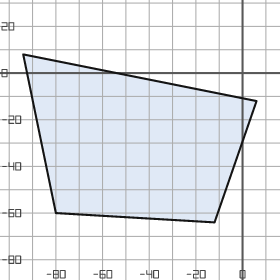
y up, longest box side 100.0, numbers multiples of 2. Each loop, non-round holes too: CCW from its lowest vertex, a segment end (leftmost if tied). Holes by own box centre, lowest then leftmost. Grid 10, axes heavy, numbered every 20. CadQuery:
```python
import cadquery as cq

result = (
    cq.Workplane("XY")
    .moveTo(-12.0, -64.0)
    .lineTo(6.0, -12.0)
    .lineTo(-94.0, 8.0)
    .lineTo(-80.0, -60.0)
    .close()
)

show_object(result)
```